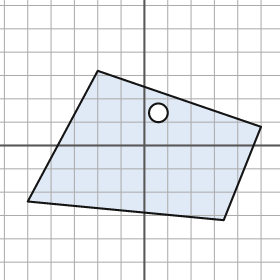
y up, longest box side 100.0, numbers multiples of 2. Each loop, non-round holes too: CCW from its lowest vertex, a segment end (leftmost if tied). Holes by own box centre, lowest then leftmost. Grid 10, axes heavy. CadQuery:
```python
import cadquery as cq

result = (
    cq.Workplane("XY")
    .moveTo(34.0, -32.0)
    .lineTo(50.0, 8.0)
    .lineTo(-20.0, 32.0)
    .lineTo(-50.0, -24.0)
    .close()
    .moveTo(6.0, 14.0)
    .circle(4.0)
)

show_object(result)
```